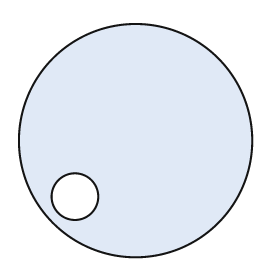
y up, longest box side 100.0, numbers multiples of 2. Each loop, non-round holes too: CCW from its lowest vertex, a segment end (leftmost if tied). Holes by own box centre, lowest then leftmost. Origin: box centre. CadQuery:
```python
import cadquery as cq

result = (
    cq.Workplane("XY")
    .moveTo(0.0, 0.0)
    .circle(50.0)
    .moveTo(-26.0, -24.0)
    .circle(10.0)
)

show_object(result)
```